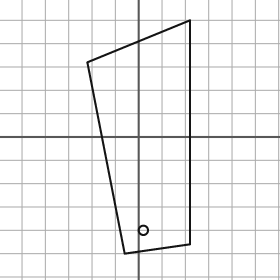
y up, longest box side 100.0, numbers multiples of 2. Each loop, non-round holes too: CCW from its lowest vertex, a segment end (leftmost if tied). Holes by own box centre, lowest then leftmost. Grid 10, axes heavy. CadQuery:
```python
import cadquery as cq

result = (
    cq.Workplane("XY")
    .moveTo(-6.0, -50.0)
    .lineTo(22.0, -46.0)
    .lineTo(22.0, 50.0)
    .lineTo(-22.0, 32.0)
    .close()
    .moveTo(2.0, -40.0)
    .circle(2.0)
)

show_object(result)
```